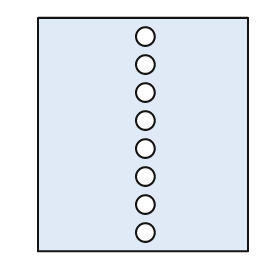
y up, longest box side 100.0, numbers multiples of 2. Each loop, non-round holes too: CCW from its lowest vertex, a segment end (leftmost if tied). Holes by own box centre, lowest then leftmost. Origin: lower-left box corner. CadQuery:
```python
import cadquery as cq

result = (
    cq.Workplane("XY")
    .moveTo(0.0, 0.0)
    .lineTo(90.0, 0.0)
    .lineTo(90.0, 100.0)
    .lineTo(0.0, 100.0)
    .close()
    .moveTo(46.0, 8.0)
    .circle(4.0)
    .moveTo(46.0, 20.0)
    .circle(4.0)
    .moveTo(46.0, 32.0)
    .circle(4.0)
    .moveTo(46.0, 44.0)
    .circle(4.0)
    .moveTo(46.0, 56.0)
    .circle(4.0)
    .moveTo(46.0, 68.0)
    .circle(4.0)
    .moveTo(46.0, 80.0)
    .circle(4.0)
    .moveTo(46.0, 92.0)
    .circle(4.0)
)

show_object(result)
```